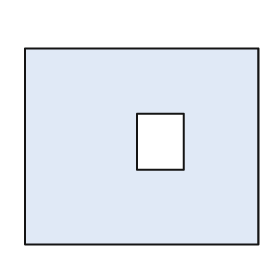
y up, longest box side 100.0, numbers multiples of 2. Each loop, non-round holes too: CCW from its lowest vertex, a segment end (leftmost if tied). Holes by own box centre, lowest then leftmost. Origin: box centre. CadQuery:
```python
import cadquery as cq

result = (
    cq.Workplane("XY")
    .moveTo(-50.0, -42.0)
    .lineTo(50.0, -42.0)
    .lineTo(50.0, 42.0)
    .lineTo(-50.0, 42.0)
    .close()
    .moveTo(-2.0, -10.0)
    .lineTo(18.0, -10.0)
    .lineTo(18.0, 14.0)
    .lineTo(-2.0, 14.0)
    .close()
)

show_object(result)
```